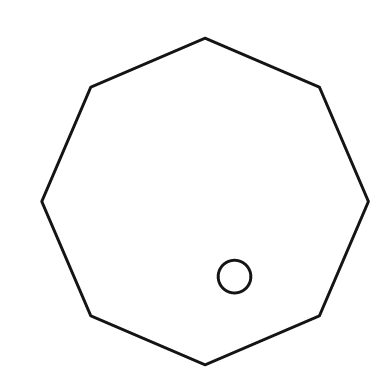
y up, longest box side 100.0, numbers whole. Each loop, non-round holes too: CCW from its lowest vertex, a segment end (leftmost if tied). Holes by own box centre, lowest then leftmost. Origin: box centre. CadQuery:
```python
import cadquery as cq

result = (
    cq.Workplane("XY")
    .moveTo(0.0, -50.0)
    .lineTo(35.0, -35.0)
    .lineTo(50.0, 0.0)
    .lineTo(35.0, 35.0)
    .lineTo(0.0, 50.0)
    .lineTo(-35.0, 35.0)
    .lineTo(-50.0, 0.0)
    .lineTo(-35.0, -35.0)
    .close()
    .moveTo(9.0, -23.0)
    .circle(5.0)
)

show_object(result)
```